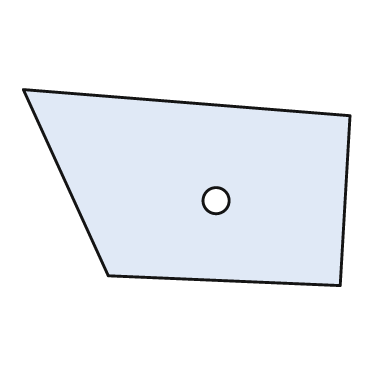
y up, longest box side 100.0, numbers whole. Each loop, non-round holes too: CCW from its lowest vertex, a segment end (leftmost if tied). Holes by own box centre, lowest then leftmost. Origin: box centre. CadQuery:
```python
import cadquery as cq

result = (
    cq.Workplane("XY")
    .moveTo(47.0, -30.0)
    .lineTo(50.0, 22.0)
    .lineTo(-50.0, 30.0)
    .lineTo(-24.0, -27.0)
    .close()
    .moveTo(9.0, -4.0)
    .circle(4.0)
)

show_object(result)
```